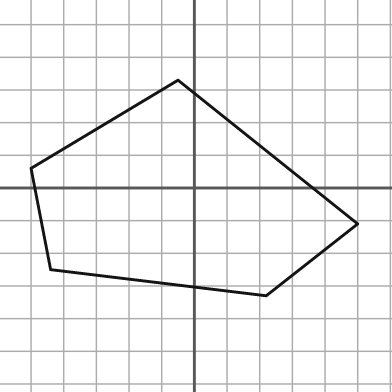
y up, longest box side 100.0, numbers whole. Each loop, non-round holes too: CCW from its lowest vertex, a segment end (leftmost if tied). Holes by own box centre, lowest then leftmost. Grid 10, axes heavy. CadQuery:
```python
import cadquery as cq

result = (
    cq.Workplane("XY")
    .moveTo(22.0, -33.0)
    .lineTo(50.0, -11.0)
    .lineTo(-5.0, 33.0)
    .lineTo(-50.0, 6.0)
    .lineTo(-44.0, -25.0)
    .close()
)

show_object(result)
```